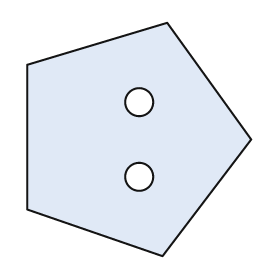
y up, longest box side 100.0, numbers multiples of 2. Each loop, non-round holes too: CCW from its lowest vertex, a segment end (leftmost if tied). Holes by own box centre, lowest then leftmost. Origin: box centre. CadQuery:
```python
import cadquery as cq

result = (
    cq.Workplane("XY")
    .moveTo(10.0, -50.0)
    .lineTo(48.0, 0.0)
    .lineTo(12.0, 50.0)
    .lineTo(-48.0, 32.0)
    .lineTo(-48.0, -30.0)
    .close()
    .moveTo(0.0, -16.0)
    .circle(6.0)
    .moveTo(0.0, 16.0)
    .circle(6.0)
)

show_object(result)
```